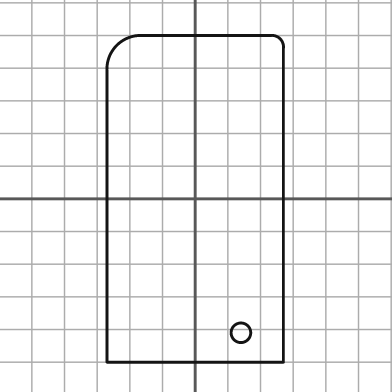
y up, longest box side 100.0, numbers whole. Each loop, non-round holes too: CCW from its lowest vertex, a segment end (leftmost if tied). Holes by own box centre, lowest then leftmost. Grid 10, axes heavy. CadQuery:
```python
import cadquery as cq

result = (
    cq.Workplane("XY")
    .moveTo(-27.0, -50.0)
    .lineTo(27.0, -50.0)
    .lineTo(27.0, 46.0)
    .threePointArc((26.0, 49.0), (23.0, 50.0))
    .lineTo(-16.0, 50.0)
    .threePointArc((-24.0, 47.0), (-27.0, 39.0))
    .close()
    .moveTo(14.0, -41.0)
    .circle(3.0)
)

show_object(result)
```